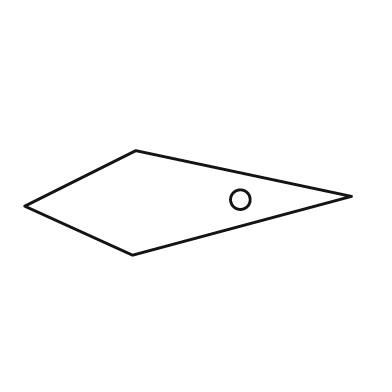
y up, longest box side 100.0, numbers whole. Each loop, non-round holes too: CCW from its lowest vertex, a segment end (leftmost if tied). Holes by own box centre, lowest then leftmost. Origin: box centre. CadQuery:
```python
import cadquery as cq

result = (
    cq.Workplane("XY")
    .moveTo(-17.0, -16.0)
    .lineTo(50.0, 2.0)
    .lineTo(-16.0, 16.0)
    .lineTo(-50.0, -1.0)
    .close()
    .moveTo(16.0, 1.0)
    .circle(3.0)
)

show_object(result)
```